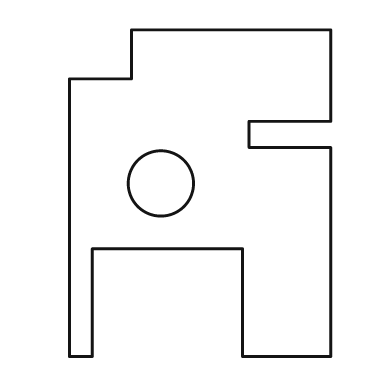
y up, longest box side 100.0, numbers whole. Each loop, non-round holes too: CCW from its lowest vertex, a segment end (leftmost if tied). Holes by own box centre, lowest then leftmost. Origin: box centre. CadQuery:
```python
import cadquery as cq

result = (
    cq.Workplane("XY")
    .moveTo(-40.0, -50.0)
    .lineTo(-33.0, -50.0)
    .lineTo(-33.0, -17.0)
    .lineTo(13.0, -17.0)
    .lineTo(13.0, -50.0)
    .lineTo(40.0, -50.0)
    .lineTo(40.0, 14.0)
    .lineTo(15.0, 14.0)
    .lineTo(15.0, 22.0)
    .lineTo(40.0, 22.0)
    .lineTo(40.0, 50.0)
    .lineTo(-21.0, 50.0)
    .lineTo(-21.0, 35.0)
    .lineTo(-40.0, 35.0)
    .close()
    .moveTo(-12.0, 3.0)
    .circle(10.0)
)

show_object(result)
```